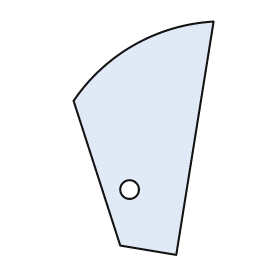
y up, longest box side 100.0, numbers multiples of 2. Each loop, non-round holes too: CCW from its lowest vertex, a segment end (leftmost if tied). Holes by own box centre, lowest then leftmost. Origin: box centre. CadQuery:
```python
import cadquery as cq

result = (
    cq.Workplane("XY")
    .moveTo(14.0, -50.0)
    .lineTo(30.0, 50.0)
    .threePointArc((-4.0, 40.0), (-30.0, 16.0))
    .lineTo(-10.0, -46.0)
    .close()
    .moveTo(-6.0, -22.0)
    .circle(4.0)
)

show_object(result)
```